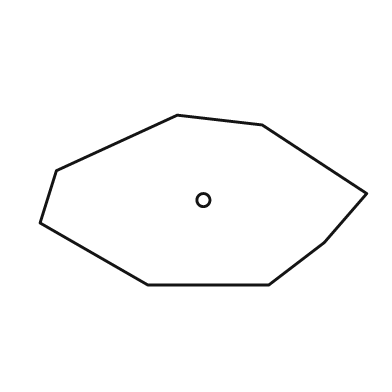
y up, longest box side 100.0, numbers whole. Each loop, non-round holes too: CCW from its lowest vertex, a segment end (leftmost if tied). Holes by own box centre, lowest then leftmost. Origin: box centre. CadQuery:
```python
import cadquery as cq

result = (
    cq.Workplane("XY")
    .moveTo(-17.0, -26.0)
    .lineTo(20.0, -26.0)
    .lineTo(37.0, -13.0)
    .lineTo(50.0, 2.0)
    .lineTo(18.0, 23.0)
    .lineTo(-8.0, 26.0)
    .lineTo(-45.0, 9.0)
    .lineTo(-50.0, -7.0)
    .close()
    .moveTo(0.0, 0.0)
    .circle(2.0)
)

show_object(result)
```